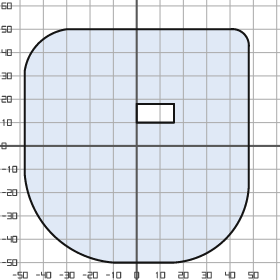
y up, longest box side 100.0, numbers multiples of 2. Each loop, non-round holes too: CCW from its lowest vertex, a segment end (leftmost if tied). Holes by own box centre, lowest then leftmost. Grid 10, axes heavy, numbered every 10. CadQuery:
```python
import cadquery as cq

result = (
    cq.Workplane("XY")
    .moveTo(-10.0, -50.0)
    .lineTo(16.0, -50.0)
    .threePointArc((38.0, -40.0), (48.0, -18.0))
    .lineTo(48.0, 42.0)
    .threePointArc((46.0, 48.0), (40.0, 50.0))
    .lineTo(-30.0, 50.0)
    .threePointArc((-42.0, 44.0), (-48.0, 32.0))
    .lineTo(-48.0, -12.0)
    .threePointArc((-36.0, -38.0), (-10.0, -50.0))
    .close()
    .moveTo(0.0, 10.0)
    .lineTo(16.0, 10.0)
    .lineTo(16.0, 18.0)
    .lineTo(0.0, 18.0)
    .close()
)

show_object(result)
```